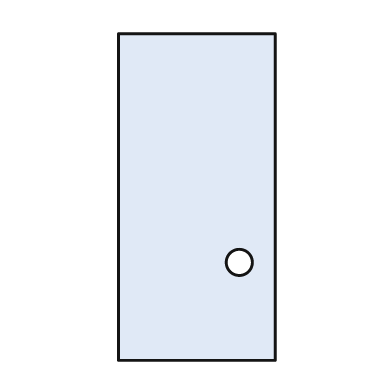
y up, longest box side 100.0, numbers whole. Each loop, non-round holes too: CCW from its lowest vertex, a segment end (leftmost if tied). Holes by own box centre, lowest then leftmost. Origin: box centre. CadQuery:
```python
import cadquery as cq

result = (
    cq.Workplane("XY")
    .moveTo(-24.0, -50.0)
    .lineTo(24.0, -50.0)
    .lineTo(24.0, 50.0)
    .lineTo(-24.0, 50.0)
    .close()
    .moveTo(13.0, -20.0)
    .circle(4.0)
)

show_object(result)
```